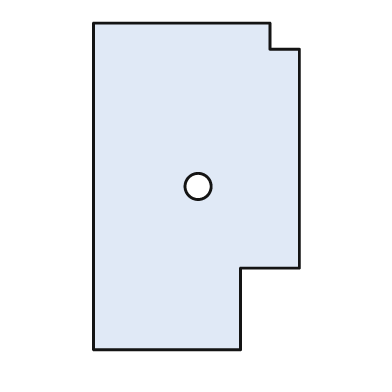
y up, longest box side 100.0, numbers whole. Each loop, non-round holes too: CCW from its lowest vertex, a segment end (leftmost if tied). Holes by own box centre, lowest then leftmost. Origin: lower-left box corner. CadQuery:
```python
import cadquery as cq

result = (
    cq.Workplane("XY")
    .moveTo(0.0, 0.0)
    .lineTo(45.0, 0.0)
    .lineTo(45.0, 25.0)
    .lineTo(63.0, 25.0)
    .lineTo(63.0, 92.0)
    .lineTo(54.0, 92.0)
    .lineTo(54.0, 100.0)
    .lineTo(0.0, 100.0)
    .close()
    .moveTo(32.0, 50.0)
    .circle(4.0)
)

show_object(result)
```